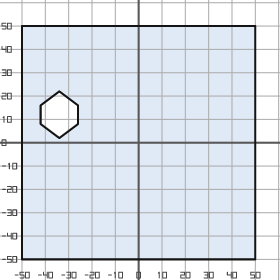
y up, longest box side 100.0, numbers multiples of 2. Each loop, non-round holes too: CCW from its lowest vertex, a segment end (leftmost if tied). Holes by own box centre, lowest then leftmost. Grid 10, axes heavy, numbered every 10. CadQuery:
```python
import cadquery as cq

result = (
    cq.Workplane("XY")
    .moveTo(-50.0, -50.0)
    .lineTo(50.0, -50.0)
    .lineTo(50.0, 50.0)
    .lineTo(-50.0, 50.0)
    .close()
    .moveTo(-34.0, 2.0)
    .lineTo(-26.0, 8.0)
    .lineTo(-26.0, 16.0)
    .lineTo(-34.0, 22.0)
    .lineTo(-42.0, 16.0)
    .lineTo(-42.0, 8.0)
    .close()
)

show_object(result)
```